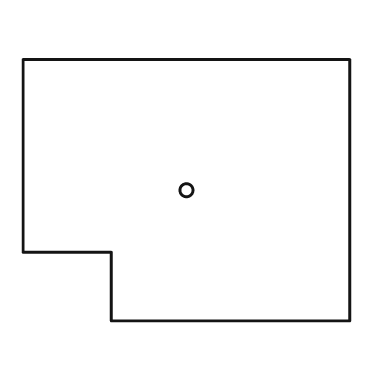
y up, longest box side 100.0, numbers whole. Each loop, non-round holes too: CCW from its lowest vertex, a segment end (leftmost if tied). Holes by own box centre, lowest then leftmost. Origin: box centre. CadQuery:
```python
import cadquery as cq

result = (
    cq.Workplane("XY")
    .moveTo(-23.0, -40.0)
    .lineTo(50.0, -40.0)
    .lineTo(50.0, 40.0)
    .lineTo(-50.0, 40.0)
    .lineTo(-50.0, -19.0)
    .lineTo(-23.0, -19.0)
    .close()
    .moveTo(0.0, 0.0)
    .circle(2.0)
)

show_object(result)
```